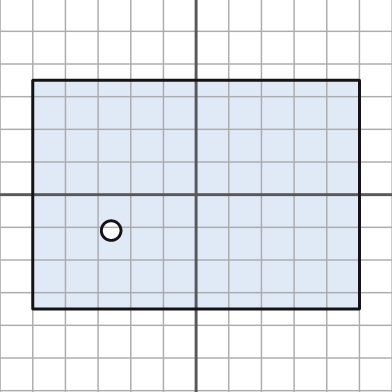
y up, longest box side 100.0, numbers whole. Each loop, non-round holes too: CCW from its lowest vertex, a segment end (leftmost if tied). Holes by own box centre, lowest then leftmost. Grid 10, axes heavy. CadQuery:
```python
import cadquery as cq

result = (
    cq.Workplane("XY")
    .moveTo(-50.0, -35.0)
    .lineTo(50.0, -35.0)
    .lineTo(50.0, 35.0)
    .lineTo(-50.0, 35.0)
    .close()
    .moveTo(-26.0, -11.0)
    .circle(3.0)
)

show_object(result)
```